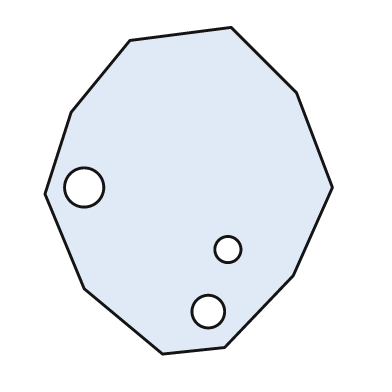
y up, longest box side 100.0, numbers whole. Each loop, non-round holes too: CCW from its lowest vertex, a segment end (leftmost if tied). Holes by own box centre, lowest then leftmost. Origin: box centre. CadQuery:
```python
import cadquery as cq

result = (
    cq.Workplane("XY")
    .moveTo(-8.0, -50.0)
    .lineTo(11.0, -48.0)
    .lineTo(32.0, -26.0)
    .lineTo(44.0, 1.0)
    .lineTo(33.0, 30.0)
    .lineTo(13.0, 50.0)
    .lineTo(-18.0, 46.0)
    .lineTo(-36.0, 24.0)
    .lineTo(-44.0, -1.0)
    .lineTo(-32.0, -30.0)
    .close()
    .moveTo(6.0, -37.0)
    .circle(5.0)
    .moveTo(12.0, -18.0)
    .circle(4.0)
    .moveTo(-32.0, 1.0)
    .circle(6.0)
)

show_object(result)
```